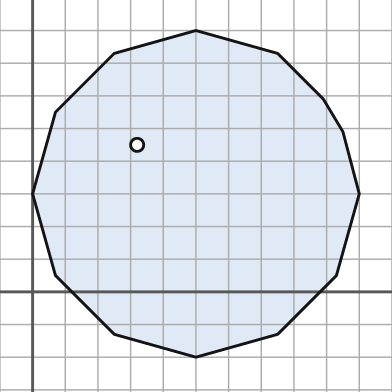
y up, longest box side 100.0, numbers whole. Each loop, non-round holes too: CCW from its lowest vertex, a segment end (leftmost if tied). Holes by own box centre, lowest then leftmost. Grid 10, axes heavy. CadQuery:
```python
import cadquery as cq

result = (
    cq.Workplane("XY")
    .moveTo(50.0, -20.0)
    .lineTo(75.0, -13.0)
    .lineTo(93.0, 5.0)
    .lineTo(100.0, 30.0)
    .lineTo(95.0, 49.0)
    .lineTo(89.0, 59.0)
    .lineTo(75.0, 73.0)
    .lineTo(50.0, 80.0)
    .lineTo(25.0, 73.0)
    .lineTo(7.0, 55.0)
    .lineTo(0.0, 30.0)
    .lineTo(7.0, 5.0)
    .lineTo(25.0, -13.0)
    .close()
    .moveTo(32.0, 45.0)
    .circle(2.0)
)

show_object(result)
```